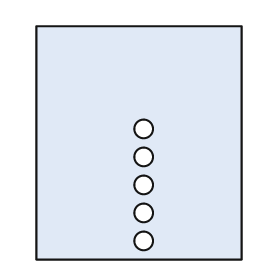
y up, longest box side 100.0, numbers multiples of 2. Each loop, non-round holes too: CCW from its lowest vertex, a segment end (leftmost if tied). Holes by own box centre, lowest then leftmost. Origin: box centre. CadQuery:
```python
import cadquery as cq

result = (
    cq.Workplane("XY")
    .moveTo(-44.0, -50.0)
    .lineTo(44.0, -50.0)
    .lineTo(44.0, 50.0)
    .lineTo(-44.0, 50.0)
    .close()
    .moveTo(2.0, -42.0)
    .circle(4.0)
    .moveTo(2.0, -30.0)
    .circle(4.0)
    .moveTo(2.0, -18.0)
    .circle(4.0)
    .moveTo(2.0, -6.0)
    .circle(4.0)
    .moveTo(2.0, 6.0)
    .circle(4.0)
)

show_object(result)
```